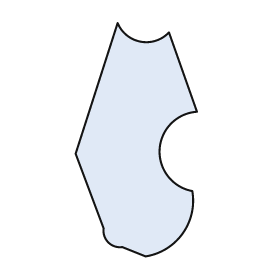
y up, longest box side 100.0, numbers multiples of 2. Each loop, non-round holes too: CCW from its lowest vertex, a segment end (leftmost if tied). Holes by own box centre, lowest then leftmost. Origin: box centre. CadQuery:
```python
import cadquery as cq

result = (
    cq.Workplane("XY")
    .moveTo(4.0, -50.0)
    .threePointArc((20.0, -40.0), (24.0, -22.0))
    .threePointArc((10.0, -4.0), (26.0, 12.0))
    .lineTo(14.0, 46.0)
    .threePointArc((2.0, 42.0), (-8.0, 50.0))
    .lineTo(-26.0, -6.0)
    .lineTo(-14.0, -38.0)
    .threePointArc((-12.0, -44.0), (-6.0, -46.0))
    .close()
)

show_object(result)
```